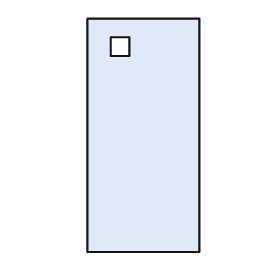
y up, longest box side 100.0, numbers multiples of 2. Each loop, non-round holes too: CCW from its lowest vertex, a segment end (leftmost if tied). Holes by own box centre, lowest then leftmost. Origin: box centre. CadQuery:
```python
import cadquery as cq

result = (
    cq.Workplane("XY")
    .moveTo(-24.0, -50.0)
    .lineTo(24.0, -50.0)
    .lineTo(24.0, 50.0)
    .lineTo(-24.0, 50.0)
    .close()
    .moveTo(-14.0, 34.0)
    .lineTo(-6.0, 34.0)
    .lineTo(-6.0, 42.0)
    .lineTo(-14.0, 42.0)
    .close()
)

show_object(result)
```